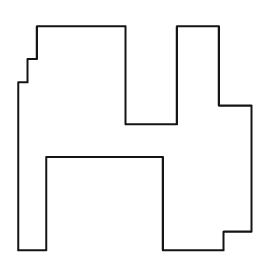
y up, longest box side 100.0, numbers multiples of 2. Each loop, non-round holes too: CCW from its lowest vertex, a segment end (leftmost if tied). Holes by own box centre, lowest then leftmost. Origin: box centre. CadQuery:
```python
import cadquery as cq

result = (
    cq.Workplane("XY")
    .moveTo(-50.0, -48.0)
    .lineTo(-38.0, -48.0)
    .lineTo(-38.0, -8.0)
    .lineTo(12.0, -8.0)
    .lineTo(12.0, -48.0)
    .lineTo(38.0, -48.0)
    .lineTo(38.0, -40.0)
    .lineTo(50.0, -40.0)
    .lineTo(50.0, 14.0)
    .lineTo(36.0, 14.0)
    .lineTo(36.0, 48.0)
    .lineTo(18.0, 48.0)
    .lineTo(18.0, 6.0)
    .lineTo(-4.0, 6.0)
    .lineTo(-4.0, 48.0)
    .lineTo(-42.0, 48.0)
    .lineTo(-42.0, 34.0)
    .lineTo(-46.0, 34.0)
    .lineTo(-46.0, 24.0)
    .lineTo(-50.0, 24.0)
    .close()
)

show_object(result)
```